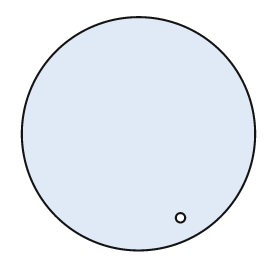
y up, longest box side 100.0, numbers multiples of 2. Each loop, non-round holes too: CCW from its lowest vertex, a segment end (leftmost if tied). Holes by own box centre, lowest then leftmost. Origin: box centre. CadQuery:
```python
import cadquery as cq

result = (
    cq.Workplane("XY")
    .moveTo(0.0, 0.0)
    .circle(50.0)
    .moveTo(18.0, -36.0)
    .circle(2.0)
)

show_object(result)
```